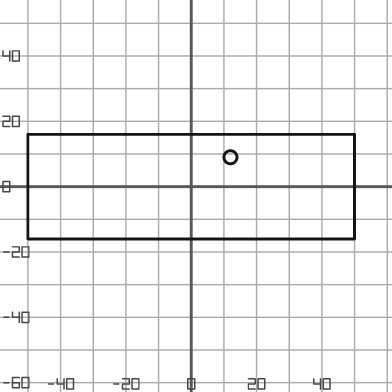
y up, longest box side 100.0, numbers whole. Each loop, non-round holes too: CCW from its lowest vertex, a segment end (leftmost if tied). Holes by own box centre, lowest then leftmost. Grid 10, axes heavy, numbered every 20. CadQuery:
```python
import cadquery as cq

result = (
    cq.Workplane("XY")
    .moveTo(-50.0, -16.0)
    .lineTo(50.0, -16.0)
    .lineTo(50.0, 16.0)
    .lineTo(-50.0, 16.0)
    .close()
    .moveTo(12.0, 9.0)
    .circle(2.0)
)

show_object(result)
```